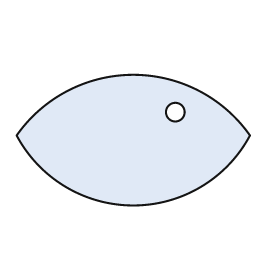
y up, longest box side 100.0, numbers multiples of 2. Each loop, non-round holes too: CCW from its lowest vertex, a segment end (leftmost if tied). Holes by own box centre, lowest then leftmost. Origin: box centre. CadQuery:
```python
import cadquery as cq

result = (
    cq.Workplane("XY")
    .moveTo(-50.0, 2.0)
    .threePointArc((0.0, -28.0), (50.0, 2.0))
    .threePointArc((0.0, 28.0), (-50.0, 2.0))
    .close()
    .moveTo(18.0, 12.0)
    .circle(4.0)
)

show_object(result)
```